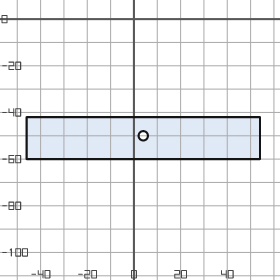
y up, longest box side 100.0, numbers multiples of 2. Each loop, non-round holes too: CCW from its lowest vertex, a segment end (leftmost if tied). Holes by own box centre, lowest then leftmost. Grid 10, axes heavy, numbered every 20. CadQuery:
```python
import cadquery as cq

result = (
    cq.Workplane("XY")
    .moveTo(-46.0, -60.0)
    .lineTo(54.0, -60.0)
    .lineTo(54.0, -42.0)
    .lineTo(-46.0, -42.0)
    .close()
    .moveTo(4.0, -50.0)
    .circle(2.0)
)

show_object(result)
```